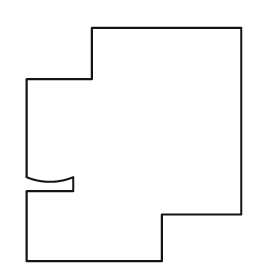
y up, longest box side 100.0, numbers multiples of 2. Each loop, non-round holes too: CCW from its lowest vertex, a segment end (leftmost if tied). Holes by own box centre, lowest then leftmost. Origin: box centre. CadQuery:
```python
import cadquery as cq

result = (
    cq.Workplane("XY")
    .moveTo(-46.0, -50.0)
    .lineTo(12.0, -50.0)
    .lineTo(12.0, -30.0)
    .lineTo(46.0, -30.0)
    .lineTo(46.0, 50.0)
    .lineTo(-18.0, 50.0)
    .lineTo(-18.0, 28.0)
    .lineTo(-46.0, 28.0)
    .lineTo(-46.0, -14.0)
    .threePointArc((-36.0, -16.0), (-26.0, -14.0))
    .lineTo(-26.0, -20.0)
    .lineTo(-46.0, -20.0)
    .close()
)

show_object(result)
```